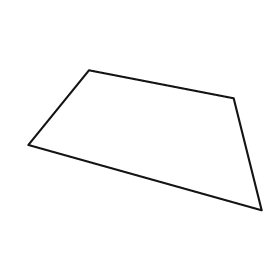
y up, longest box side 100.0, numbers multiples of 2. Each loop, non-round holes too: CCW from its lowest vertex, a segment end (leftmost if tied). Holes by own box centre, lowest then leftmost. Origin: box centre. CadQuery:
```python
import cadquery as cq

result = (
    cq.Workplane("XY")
    .moveTo(50.0, -30.0)
    .lineTo(38.0, 18.0)
    .lineTo(-24.0, 30.0)
    .lineTo(-50.0, -2.0)
    .close()
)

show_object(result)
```